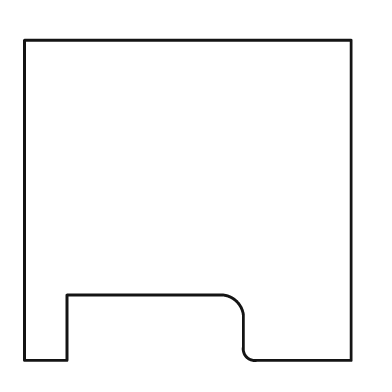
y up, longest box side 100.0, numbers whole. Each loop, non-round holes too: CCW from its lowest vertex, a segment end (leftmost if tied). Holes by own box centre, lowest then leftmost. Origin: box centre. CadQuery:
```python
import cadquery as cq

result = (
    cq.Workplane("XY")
    .moveTo(-50.0, -49.0)
    .lineTo(-37.0, -49.0)
    .lineTo(-37.0, -29.0)
    .lineTo(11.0, -29.0)
    .threePointArc((15.0, -31.0), (17.0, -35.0))
    .lineTo(17.0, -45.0)
    .threePointArc((18.0, -48.0), (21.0, -49.0))
    .lineTo(50.0, -49.0)
    .lineTo(50.0, 49.0)
    .lineTo(-50.0, 49.0)
    .close()
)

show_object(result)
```